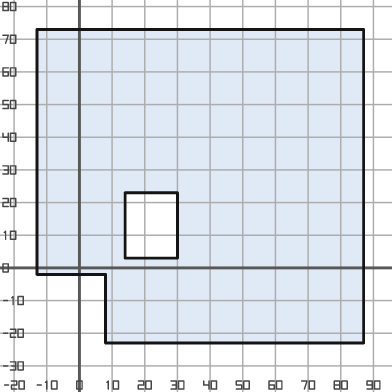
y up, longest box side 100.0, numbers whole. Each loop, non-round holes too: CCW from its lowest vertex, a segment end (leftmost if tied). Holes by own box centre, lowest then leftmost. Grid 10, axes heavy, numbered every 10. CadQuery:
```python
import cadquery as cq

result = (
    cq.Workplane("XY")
    .moveTo(8.0, -23.0)
    .lineTo(87.0, -23.0)
    .lineTo(87.0, 73.0)
    .lineTo(-13.0, 73.0)
    .lineTo(-13.0, -2.0)
    .lineTo(8.0, -2.0)
    .close()
    .moveTo(14.0, 3.0)
    .lineTo(30.0, 3.0)
    .lineTo(30.0, 23.0)
    .lineTo(14.0, 23.0)
    .close()
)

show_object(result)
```